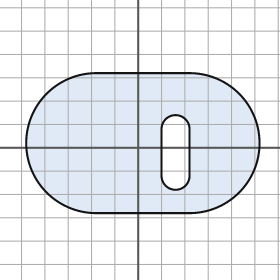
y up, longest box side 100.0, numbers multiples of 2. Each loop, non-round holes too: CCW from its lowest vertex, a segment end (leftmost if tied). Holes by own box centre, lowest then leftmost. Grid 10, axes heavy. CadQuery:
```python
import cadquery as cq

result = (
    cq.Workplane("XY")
    .moveTo(-18.0, -28.0)
    .lineTo(22.0, -28.0)
    .threePointArc((52.0, 2.0), (22.0, 32.0))
    .lineTo(-18.0, 32.0)
    .threePointArc((-48.0, 2.0), (-18.0, -28.0))
    .close()
    .moveTo(10.0, -12.0)
    .threePointArc((16.0, -18.0), (22.0, -12.0))
    .lineTo(22.0, 8.0)
    .threePointArc((16.0, 14.0), (10.0, 8.0))
    .close()
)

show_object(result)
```